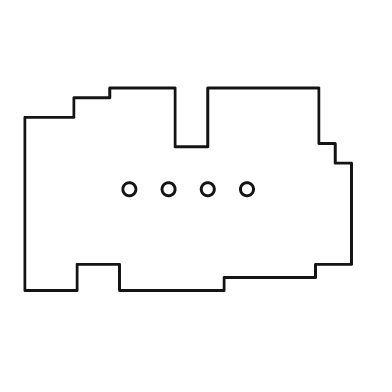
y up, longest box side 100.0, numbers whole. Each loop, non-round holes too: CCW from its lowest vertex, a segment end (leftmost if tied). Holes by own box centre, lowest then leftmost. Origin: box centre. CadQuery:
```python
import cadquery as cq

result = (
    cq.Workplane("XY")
    .moveTo(-50.0, -31.0)
    .lineTo(-34.0, -31.0)
    .lineTo(-34.0, -23.0)
    .lineTo(-21.0, -23.0)
    .lineTo(-21.0, -31.0)
    .lineTo(11.0, -31.0)
    .lineTo(11.0, -27.0)
    .lineTo(39.0, -27.0)
    .lineTo(39.0, -23.0)
    .lineTo(50.0, -23.0)
    .lineTo(50.0, 8.0)
    .lineTo(45.0, 8.0)
    .lineTo(45.0, 14.0)
    .lineTo(40.0, 14.0)
    .lineTo(40.0, 31.0)
    .lineTo(6.0, 31.0)
    .lineTo(6.0, 13.0)
    .lineTo(-4.0, 13.0)
    .lineTo(-4.0, 31.0)
    .lineTo(-24.0, 31.0)
    .lineTo(-24.0, 28.0)
    .lineTo(-35.0, 28.0)
    .lineTo(-35.0, 22.0)
    .lineTo(-50.0, 22.0)
    .close()
    .moveTo(-18.0, 0.0)
    .circle(2.0)
    .moveTo(-6.0, 0.0)
    .circle(2.0)
    .moveTo(6.0, 0.0)
    .circle(2.0)
    .moveTo(18.0, 0.0)
    .circle(2.0)
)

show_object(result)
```